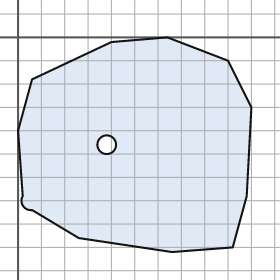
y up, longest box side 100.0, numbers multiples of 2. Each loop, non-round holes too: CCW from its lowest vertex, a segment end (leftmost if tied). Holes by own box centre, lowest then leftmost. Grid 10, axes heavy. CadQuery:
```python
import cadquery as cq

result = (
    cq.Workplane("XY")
    .moveTo(66.0, -92.0)
    .lineTo(92.0, -90.0)
    .lineTo(98.0, -68.0)
    .lineTo(100.0, -30.0)
    .lineTo(90.0, -10.0)
    .lineTo(64.0, 0.0)
    .lineTo(40.0, -2.0)
    .lineTo(6.0, -18.0)
    .lineTo(0.0, -40.0)
    .lineTo(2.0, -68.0)
    .threePointArc((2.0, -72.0), (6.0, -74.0))
    .lineTo(26.0, -86.0)
    .close()
    .moveTo(38.0, -46.0)
    .circle(4.0)
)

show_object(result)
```